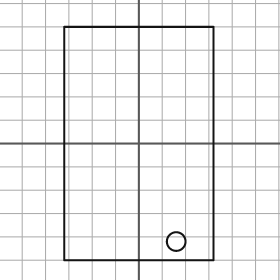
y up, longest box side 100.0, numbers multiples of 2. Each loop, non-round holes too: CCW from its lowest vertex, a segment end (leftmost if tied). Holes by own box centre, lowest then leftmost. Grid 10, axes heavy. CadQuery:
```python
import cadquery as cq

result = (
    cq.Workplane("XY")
    .moveTo(-32.0, -50.0)
    .lineTo(32.0, -50.0)
    .lineTo(32.0, 50.0)
    .lineTo(-32.0, 50.0)
    .close()
    .moveTo(16.0, -42.0)
    .circle(4.0)
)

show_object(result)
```